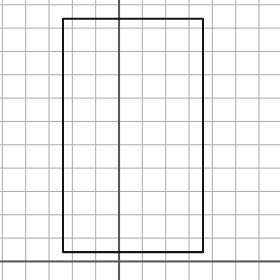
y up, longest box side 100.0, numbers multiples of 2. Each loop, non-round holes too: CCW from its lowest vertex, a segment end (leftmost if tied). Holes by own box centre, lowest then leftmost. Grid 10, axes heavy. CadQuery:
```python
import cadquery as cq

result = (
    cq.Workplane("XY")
    .moveTo(-24.0, 4.0)
    .lineTo(36.0, 4.0)
    .lineTo(36.0, 104.0)
    .lineTo(-24.0, 104.0)
    .close()
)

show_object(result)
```